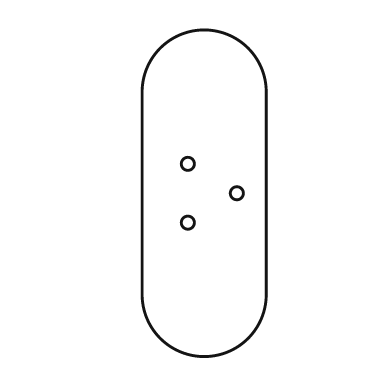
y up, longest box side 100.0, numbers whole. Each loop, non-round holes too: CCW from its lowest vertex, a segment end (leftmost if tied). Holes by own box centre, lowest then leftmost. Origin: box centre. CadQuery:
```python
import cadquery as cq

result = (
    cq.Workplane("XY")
    .moveTo(-19.0, -31.0)
    .threePointArc((0.0, -50.0), (19.0, -31.0))
    .lineTo(19.0, 31.0)
    .threePointArc((0.0, 50.0), (-19.0, 31.0))
    .close()
    .moveTo(-5.0, -9.0)
    .circle(2.0)
    .moveTo(10.0, 0.0)
    .circle(2.0)
    .moveTo(-5.0, 9.0)
    .circle(2.0)
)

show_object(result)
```